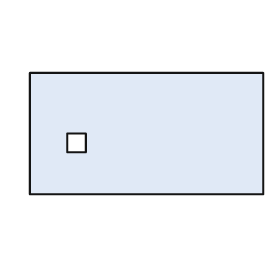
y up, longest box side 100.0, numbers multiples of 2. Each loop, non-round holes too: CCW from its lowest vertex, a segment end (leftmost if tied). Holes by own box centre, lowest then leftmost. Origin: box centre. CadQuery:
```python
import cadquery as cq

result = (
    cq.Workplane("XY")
    .moveTo(-50.0, -26.0)
    .lineTo(50.0, -26.0)
    .lineTo(50.0, 26.0)
    .lineTo(-50.0, 26.0)
    .close()
    .moveTo(-34.0, -8.0)
    .lineTo(-26.0, -8.0)
    .lineTo(-26.0, 0.0)
    .lineTo(-34.0, 0.0)
    .close()
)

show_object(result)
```